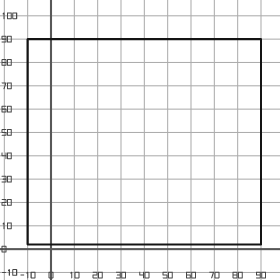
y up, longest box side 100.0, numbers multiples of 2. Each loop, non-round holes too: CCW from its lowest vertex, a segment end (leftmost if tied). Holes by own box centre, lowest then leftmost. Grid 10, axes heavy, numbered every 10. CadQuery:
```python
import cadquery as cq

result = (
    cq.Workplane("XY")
    .moveTo(-10.0, 2.0)
    .lineTo(90.0, 2.0)
    .lineTo(90.0, 90.0)
    .lineTo(-10.0, 90.0)
    .close()
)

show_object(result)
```